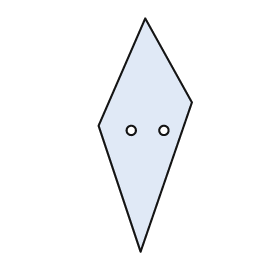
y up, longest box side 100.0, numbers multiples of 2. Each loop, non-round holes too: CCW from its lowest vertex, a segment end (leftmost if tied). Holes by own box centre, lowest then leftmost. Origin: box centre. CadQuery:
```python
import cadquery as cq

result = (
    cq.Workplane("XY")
    .moveTo(-2.0, -50.0)
    .lineTo(20.0, 14.0)
    .lineTo(0.0, 50.0)
    .lineTo(-20.0, 4.0)
    .close()
    .moveTo(-6.0, 2.0)
    .circle(2.0)
    .moveTo(8.0, 2.0)
    .circle(2.0)
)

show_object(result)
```